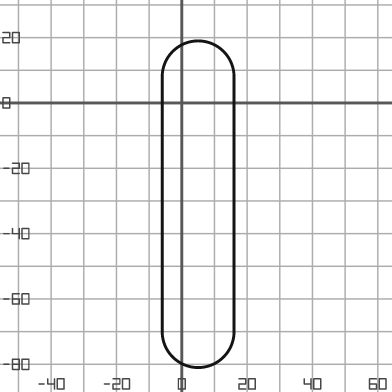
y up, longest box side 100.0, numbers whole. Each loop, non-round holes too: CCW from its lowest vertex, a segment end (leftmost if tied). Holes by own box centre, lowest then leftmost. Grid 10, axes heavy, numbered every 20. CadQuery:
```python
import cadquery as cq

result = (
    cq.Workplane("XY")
    .moveTo(-6.0, -70.0)
    .threePointArc((5.0, -81.0), (16.0, -70.0))
    .lineTo(16.0, 8.0)
    .threePointArc((5.0, 19.0), (-6.0, 8.0))
    .close()
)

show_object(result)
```